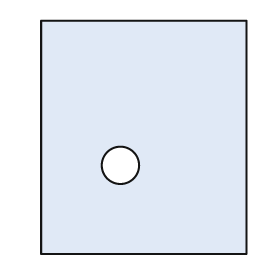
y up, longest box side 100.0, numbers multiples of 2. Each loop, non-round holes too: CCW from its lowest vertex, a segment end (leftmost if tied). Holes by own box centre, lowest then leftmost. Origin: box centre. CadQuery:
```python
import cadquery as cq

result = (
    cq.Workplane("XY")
    .moveTo(-44.0, -50.0)
    .lineTo(44.0, -50.0)
    .lineTo(44.0, 50.0)
    .lineTo(-44.0, 50.0)
    .close()
    .moveTo(-10.0, -12.0)
    .circle(8.0)
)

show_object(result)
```